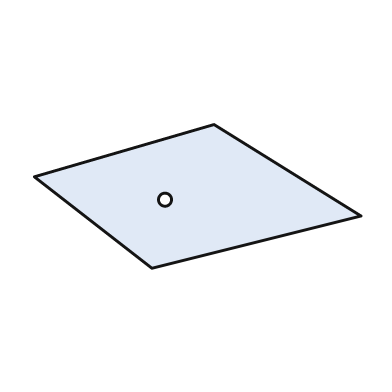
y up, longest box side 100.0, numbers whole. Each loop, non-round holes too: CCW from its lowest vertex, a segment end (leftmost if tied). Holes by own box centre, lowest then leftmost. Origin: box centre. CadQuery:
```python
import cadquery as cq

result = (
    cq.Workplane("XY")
    .moveTo(-14.0, -22.0)
    .lineTo(50.0, -6.0)
    .lineTo(5.0, 22.0)
    .lineTo(-50.0, 6.0)
    .close()
    .moveTo(-10.0, -1.0)
    .circle(2.0)
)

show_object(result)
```